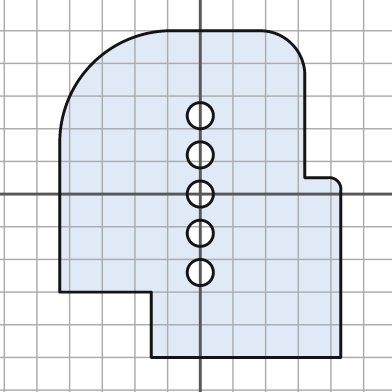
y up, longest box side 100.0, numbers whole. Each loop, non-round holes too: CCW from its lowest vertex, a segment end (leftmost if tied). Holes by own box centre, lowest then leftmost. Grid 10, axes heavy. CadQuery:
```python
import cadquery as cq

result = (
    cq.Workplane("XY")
    .moveTo(-15.0, -50.0)
    .lineTo(43.0, -50.0)
    .lineTo(43.0, 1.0)
    .threePointArc((42.0, 4.0), (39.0, 5.0))
    .lineTo(32.0, 5.0)
    .lineTo(32.0, 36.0)
    .threePointArc((28.0, 46.0), (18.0, 50.0))
    .lineTo(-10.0, 50.0)
    .threePointArc((-33.0, 40.0), (-43.0, 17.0))
    .lineTo(-43.0, -30.0)
    .lineTo(-15.0, -30.0)
    .close()
    .moveTo(0.0, -24.0)
    .circle(4.0)
    .moveTo(0.0, -12.0)
    .circle(4.0)
    .moveTo(0.0, 0.0)
    .circle(4.0)
    .moveTo(0.0, 12.0)
    .circle(4.0)
    .moveTo(0.0, 24.0)
    .circle(4.0)
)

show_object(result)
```